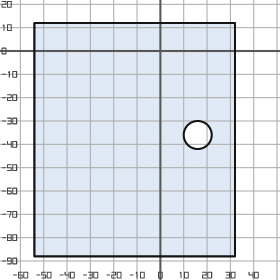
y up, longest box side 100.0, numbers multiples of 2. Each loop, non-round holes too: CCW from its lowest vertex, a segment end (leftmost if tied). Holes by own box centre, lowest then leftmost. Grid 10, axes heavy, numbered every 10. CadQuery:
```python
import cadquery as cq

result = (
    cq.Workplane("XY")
    .moveTo(-54.0, -88.0)
    .lineTo(32.0, -88.0)
    .lineTo(32.0, 12.0)
    .lineTo(-54.0, 12.0)
    .close()
    .moveTo(16.0, -36.0)
    .circle(6.0)
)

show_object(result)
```